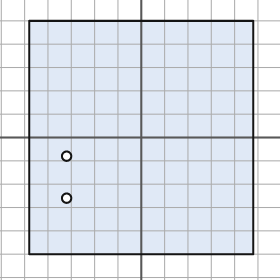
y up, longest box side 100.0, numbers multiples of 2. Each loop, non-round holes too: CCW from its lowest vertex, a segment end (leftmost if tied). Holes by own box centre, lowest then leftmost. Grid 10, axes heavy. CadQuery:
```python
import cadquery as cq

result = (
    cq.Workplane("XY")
    .moveTo(-48.0, -50.0)
    .lineTo(48.0, -50.0)
    .lineTo(48.0, 50.0)
    .lineTo(-48.0, 50.0)
    .close()
    .moveTo(-32.0, -26.0)
    .circle(2.0)
    .moveTo(-32.0, -8.0)
    .circle(2.0)
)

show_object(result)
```